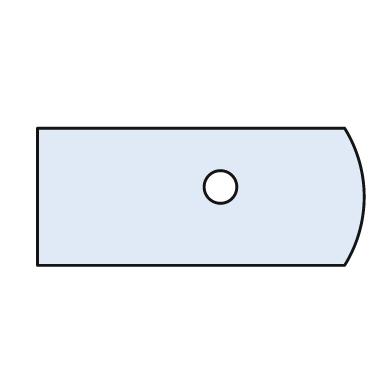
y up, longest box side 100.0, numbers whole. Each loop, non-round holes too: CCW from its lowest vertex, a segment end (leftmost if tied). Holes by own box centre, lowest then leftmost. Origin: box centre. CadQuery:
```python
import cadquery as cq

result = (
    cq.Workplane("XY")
    .moveTo(-50.0, -21.0)
    .lineTo(44.0, -21.0)
    .threePointArc((50.0, 0.0), (44.0, 21.0))
    .lineTo(-50.0, 21.0)
    .close()
    .moveTo(6.0, 3.0)
    .circle(5.0)
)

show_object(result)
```